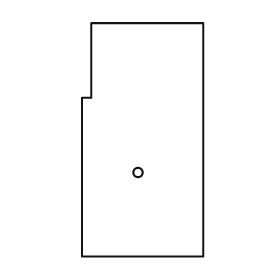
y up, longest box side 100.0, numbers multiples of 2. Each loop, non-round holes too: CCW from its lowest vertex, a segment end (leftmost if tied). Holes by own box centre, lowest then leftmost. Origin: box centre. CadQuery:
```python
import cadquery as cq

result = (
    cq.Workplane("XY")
    .moveTo(-26.0, -50.0)
    .lineTo(26.0, -50.0)
    .lineTo(26.0, 50.0)
    .lineTo(-22.0, 50.0)
    .lineTo(-22.0, 18.0)
    .lineTo(-26.0, 18.0)
    .close()
    .moveTo(-2.0, -14.0)
    .circle(2.0)
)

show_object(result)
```